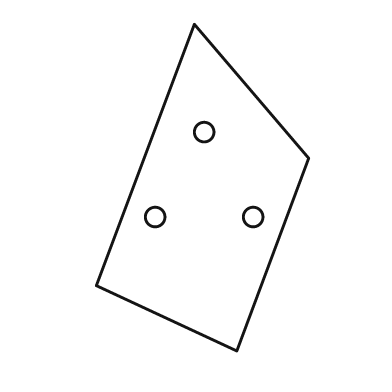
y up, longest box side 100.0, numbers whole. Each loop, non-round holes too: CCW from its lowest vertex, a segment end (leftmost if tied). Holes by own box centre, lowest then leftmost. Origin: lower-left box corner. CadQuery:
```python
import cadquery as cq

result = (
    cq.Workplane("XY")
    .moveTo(43.0, 0.0)
    .lineTo(65.0, 59.0)
    .lineTo(30.0, 100.0)
    .lineTo(0.0, 20.0)
    .close()
    .moveTo(18.0, 41.0)
    .circle(3.0)
    .moveTo(48.0, 41.0)
    .circle(3.0)
    .moveTo(33.0, 67.0)
    .circle(3.0)
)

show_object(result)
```